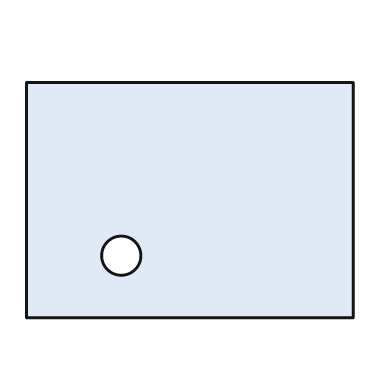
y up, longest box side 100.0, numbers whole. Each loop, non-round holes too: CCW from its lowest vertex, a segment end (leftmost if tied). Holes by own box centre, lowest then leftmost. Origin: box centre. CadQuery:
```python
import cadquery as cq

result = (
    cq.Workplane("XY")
    .moveTo(-50.0, -36.0)
    .lineTo(50.0, -36.0)
    .lineTo(50.0, 36.0)
    .lineTo(-50.0, 36.0)
    .close()
    .moveTo(-21.0, -17.0)
    .circle(6.0)
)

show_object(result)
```